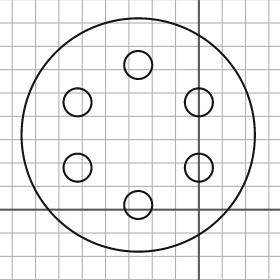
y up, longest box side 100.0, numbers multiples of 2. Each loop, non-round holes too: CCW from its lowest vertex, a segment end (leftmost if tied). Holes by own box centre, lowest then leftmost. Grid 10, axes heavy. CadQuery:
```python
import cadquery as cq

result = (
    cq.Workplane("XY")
    .moveTo(-26.0, 32.0)
    .circle(50.0)
    .moveTo(-26.0, 2.0)
    .circle(6.0)
    .moveTo(-52.0, 18.0)
    .circle(6.0)
    .moveTo(0.0, 18.0)
    .circle(6.0)
    .moveTo(-52.0, 46.0)
    .circle(6.0)
    .moveTo(0.0, 46.0)
    .circle(6.0)
    .moveTo(-26.0, 62.0)
    .circle(6.0)
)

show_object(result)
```